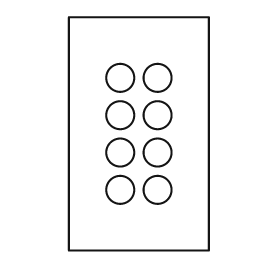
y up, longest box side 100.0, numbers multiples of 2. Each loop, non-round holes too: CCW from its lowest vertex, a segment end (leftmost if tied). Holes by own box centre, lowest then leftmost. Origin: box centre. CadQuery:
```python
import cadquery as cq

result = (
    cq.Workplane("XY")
    .moveTo(-30.0, -50.0)
    .lineTo(30.0, -50.0)
    .lineTo(30.0, 50.0)
    .lineTo(-30.0, 50.0)
    .close()
    .moveTo(-8.0, -24.0)
    .circle(6.0)
    .moveTo(8.0, -24.0)
    .circle(6.0)
    .moveTo(-8.0, -8.0)
    .circle(6.0)
    .moveTo(8.0, -8.0)
    .circle(6.0)
    .moveTo(-8.0, 8.0)
    .circle(6.0)
    .moveTo(8.0, 8.0)
    .circle(6.0)
    .moveTo(-8.0, 24.0)
    .circle(6.0)
    .moveTo(8.0, 24.0)
    .circle(6.0)
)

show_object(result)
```